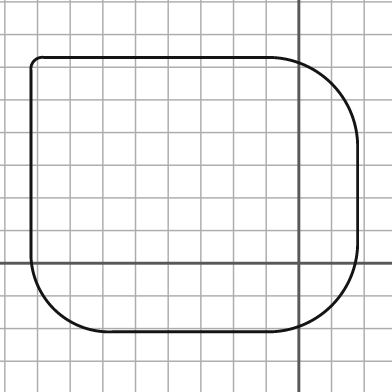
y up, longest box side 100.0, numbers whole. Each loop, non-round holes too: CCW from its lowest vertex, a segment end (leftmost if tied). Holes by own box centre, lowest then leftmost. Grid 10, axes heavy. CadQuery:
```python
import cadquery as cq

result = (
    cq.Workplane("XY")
    .moveTo(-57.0, -21.0)
    .lineTo(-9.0, -21.0)
    .threePointArc((10.0, -13.0), (18.0, 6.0))
    .lineTo(18.0, 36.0)
    .threePointArc((10.0, 55.0), (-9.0, 63.0))
    .lineTo(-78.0, 63.0)
    .threePointArc((-81.0, 62.0), (-82.0, 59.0))
    .lineTo(-82.0, 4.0)
    .threePointArc((-75.0, -14.0), (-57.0, -21.0))
    .close()
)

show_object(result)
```